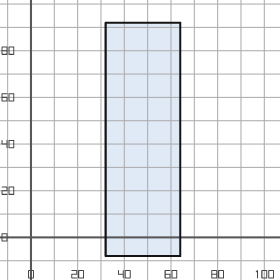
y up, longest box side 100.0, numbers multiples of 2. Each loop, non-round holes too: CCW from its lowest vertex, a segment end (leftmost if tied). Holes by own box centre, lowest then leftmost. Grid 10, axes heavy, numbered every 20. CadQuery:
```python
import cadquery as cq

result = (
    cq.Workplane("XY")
    .moveTo(32.0, -8.0)
    .lineTo(64.0, -8.0)
    .lineTo(64.0, 92.0)
    .lineTo(32.0, 92.0)
    .close()
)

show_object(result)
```